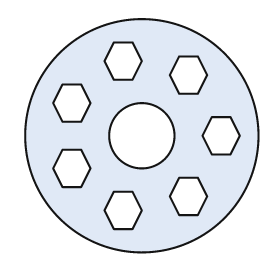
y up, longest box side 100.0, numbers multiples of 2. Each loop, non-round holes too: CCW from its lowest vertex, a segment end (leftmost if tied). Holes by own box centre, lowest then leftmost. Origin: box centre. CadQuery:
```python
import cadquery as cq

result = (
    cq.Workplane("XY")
    .moveTo(0.0, 0.0)
    .circle(50.0)
    .moveTo(-12.0, -40.0)
    .lineTo(-4.0, -40.0)
    .lineTo(0.0, -32.0)
    .lineTo(-4.0, -24.0)
    .lineTo(-12.0, -24.0)
    .lineTo(-16.0, -32.0)
    .close()
    .moveTo(16.0, -34.0)
    .lineTo(24.0, -34.0)
    .lineTo(28.0, -26.0)
    .lineTo(24.0, -18.0)
    .lineTo(16.0, -18.0)
    .lineTo(12.0, -26.0)
    .close()
    .moveTo(-34.0, -22.0)
    .lineTo(-26.0, -22.0)
    .lineTo(-22.0, -14.0)
    .lineTo(-26.0, -6.0)
    .lineTo(-34.0, -6.0)
    .lineTo(-38.0, -14.0)
    .close()
    .moveTo(0.0, 0.0)
    .circle(14.0)
    .moveTo(30.0, -8.0)
    .lineTo(38.0, -8.0)
    .lineTo(42.0, 0.0)
    .lineTo(38.0, 8.0)
    .lineTo(30.0, 8.0)
    .lineTo(26.0, 0.0)
    .close()
    .moveTo(-34.0, 6.0)
    .lineTo(-26.0, 6.0)
    .lineTo(-22.0, 14.0)
    .lineTo(-26.0, 22.0)
    .lineTo(-34.0, 22.0)
    .lineTo(-38.0, 14.0)
    .close()
    .moveTo(16.0, 18.0)
    .lineTo(24.0, 18.0)
    .lineTo(28.0, 26.0)
    .lineTo(24.0, 34.0)
    .lineTo(16.0, 34.0)
    .lineTo(12.0, 26.0)
    .close()
    .moveTo(-12.0, 24.0)
    .lineTo(-4.0, 24.0)
    .lineTo(0.0, 32.0)
    .lineTo(-4.0, 40.0)
    .lineTo(-12.0, 40.0)
    .lineTo(-16.0, 32.0)
    .close()
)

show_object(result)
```